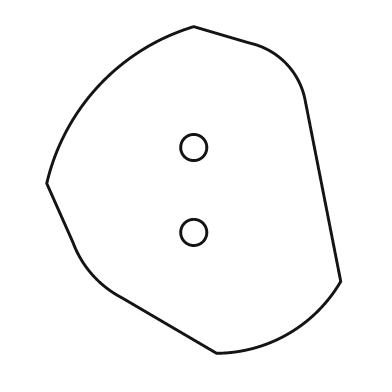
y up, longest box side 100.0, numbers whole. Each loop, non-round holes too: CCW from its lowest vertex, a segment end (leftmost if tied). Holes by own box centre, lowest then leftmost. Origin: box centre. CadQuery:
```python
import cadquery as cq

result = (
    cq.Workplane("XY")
    .moveTo(7.0, -50.0)
    .threePointArc((29.0, -44.0), (45.0, -28.0))
    .lineTo(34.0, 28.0)
    .threePointArc((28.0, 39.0), (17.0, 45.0))
    .lineTo(0.0, 50.0)
    .threePointArc((-29.0, 32.0), (-45.0, 2.0))
    .lineTo(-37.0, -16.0)
    .threePointArc((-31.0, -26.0), (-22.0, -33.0))
    .close()
    .moveTo(0.0, -13.0)
    .circle(4.0)
    .moveTo(0.0, 13.0)
    .circle(4.0)
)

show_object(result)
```